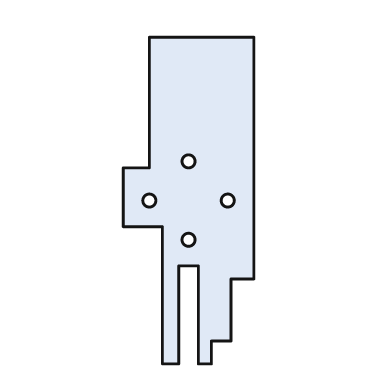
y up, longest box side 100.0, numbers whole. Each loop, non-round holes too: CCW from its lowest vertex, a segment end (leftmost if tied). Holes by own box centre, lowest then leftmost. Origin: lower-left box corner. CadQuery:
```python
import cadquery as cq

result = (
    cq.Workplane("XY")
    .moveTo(12.0, 0.0)
    .lineTo(17.0, 0.0)
    .lineTo(17.0, 30.0)
    .lineTo(23.0, 30.0)
    .lineTo(23.0, 0.0)
    .lineTo(27.0, 0.0)
    .lineTo(27.0, 7.0)
    .lineTo(33.0, 7.0)
    .lineTo(33.0, 26.0)
    .lineTo(40.0, 26.0)
    .lineTo(40.0, 100.0)
    .lineTo(8.0, 100.0)
    .lineTo(8.0, 60.0)
    .lineTo(0.0, 60.0)
    .lineTo(0.0, 42.0)
    .lineTo(12.0, 42.0)
    .close()
    .moveTo(20.0, 38.0)
    .circle(2.0)
    .moveTo(8.0, 50.0)
    .circle(2.0)
    .moveTo(32.0, 50.0)
    .circle(2.0)
    .moveTo(20.0, 62.0)
    .circle(2.0)
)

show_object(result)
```